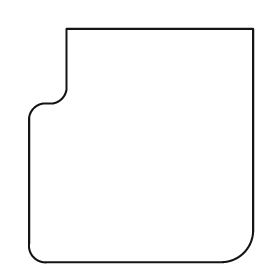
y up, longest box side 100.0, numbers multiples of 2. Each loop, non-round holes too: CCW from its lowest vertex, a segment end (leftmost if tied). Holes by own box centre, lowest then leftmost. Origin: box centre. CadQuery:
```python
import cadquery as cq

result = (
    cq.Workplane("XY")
    .moveTo(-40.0, -50.0)
    .lineTo(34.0, -50.0)
    .threePointArc((44.0, -46.0), (48.0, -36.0))
    .lineTo(48.0, 50.0)
    .lineTo(-32.0, 50.0)
    .lineTo(-32.0, 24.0)
    .threePointArc((-34.0, 20.0), (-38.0, 18.0))
    .lineTo(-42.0, 18.0)
    .threePointArc((-46.0, 16.0), (-48.0, 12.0))
    .lineTo(-48.0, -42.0)
    .threePointArc((-46.0, -48.0), (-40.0, -50.0))
    .close()
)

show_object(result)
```